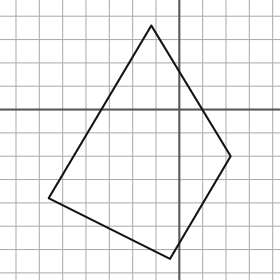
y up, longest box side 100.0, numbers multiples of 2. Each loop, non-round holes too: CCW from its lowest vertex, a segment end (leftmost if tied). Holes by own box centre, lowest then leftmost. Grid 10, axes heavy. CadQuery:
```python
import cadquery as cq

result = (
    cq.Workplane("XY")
    .moveTo(-4.0, -64.0)
    .lineTo(22.0, -20.0)
    .lineTo(-12.0, 36.0)
    .lineTo(-56.0, -38.0)
    .close()
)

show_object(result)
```